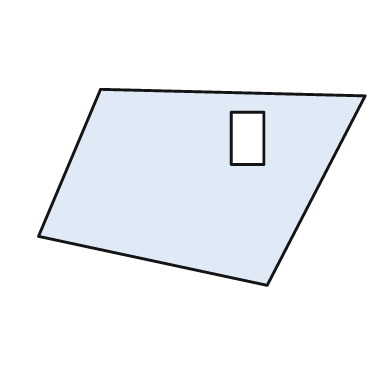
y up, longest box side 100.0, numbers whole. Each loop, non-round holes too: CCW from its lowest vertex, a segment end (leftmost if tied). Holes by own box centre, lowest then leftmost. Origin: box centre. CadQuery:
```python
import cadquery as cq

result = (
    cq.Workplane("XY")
    .moveTo(20.0, -30.0)
    .lineTo(50.0, 28.0)
    .lineTo(-31.0, 30.0)
    .lineTo(-50.0, -15.0)
    .close()
    .moveTo(9.0, 7.0)
    .lineTo(19.0, 7.0)
    .lineTo(19.0, 23.0)
    .lineTo(9.0, 23.0)
    .close()
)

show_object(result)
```